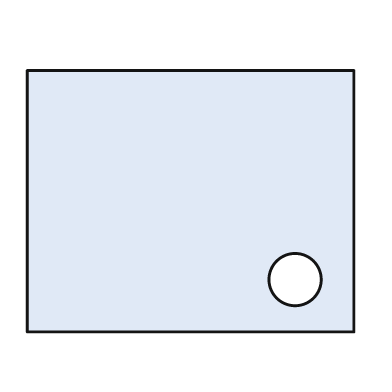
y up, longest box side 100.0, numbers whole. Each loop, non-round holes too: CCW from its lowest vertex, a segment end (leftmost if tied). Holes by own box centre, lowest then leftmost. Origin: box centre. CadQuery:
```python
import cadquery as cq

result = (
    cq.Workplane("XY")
    .moveTo(-50.0, -40.0)
    .lineTo(50.0, -40.0)
    .lineTo(50.0, 40.0)
    .lineTo(-50.0, 40.0)
    .close()
    .moveTo(32.0, -24.0)
    .circle(8.0)
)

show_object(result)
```